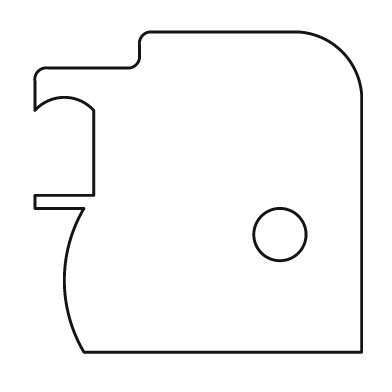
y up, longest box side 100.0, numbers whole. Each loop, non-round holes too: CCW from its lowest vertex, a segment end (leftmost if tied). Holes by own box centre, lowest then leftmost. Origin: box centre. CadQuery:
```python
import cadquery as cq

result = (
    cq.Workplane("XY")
    .moveTo(-35.0, -49.0)
    .lineTo(50.0, -49.0)
    .lineTo(50.0, 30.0)
    .threePointArc((44.0, 43.0), (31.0, 49.0))
    .lineTo(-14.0, 49.0)
    .threePointArc((-17.0, 48.0), (-18.0, 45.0))
    .lineTo(-18.0, 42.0)
    .threePointArc((-19.0, 39.0), (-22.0, 38.0))
    .lineTo(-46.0, 38.0)
    .threePointArc((-49.0, 37.0), (-50.0, 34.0))
    .lineTo(-50.0, 25.0)
    .threePointArc((-41.0, 29.0), (-32.0, 25.0))
    .lineTo(-32.0, -1.0)
    .lineTo(-50.0, -1.0)
    .lineTo(-50.0, -5.0)
    .lineTo(-35.0, -5.0)
    .threePointArc((-41.0, -27.0), (-35.0, -49.0))
    .close()
    .moveTo(25.0, -13.0)
    .circle(8.0)
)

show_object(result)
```